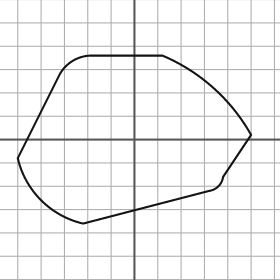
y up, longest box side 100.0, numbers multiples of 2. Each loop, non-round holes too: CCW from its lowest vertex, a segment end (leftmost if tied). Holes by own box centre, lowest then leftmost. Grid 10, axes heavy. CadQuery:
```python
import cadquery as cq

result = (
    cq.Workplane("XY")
    .moveTo(-22.0, -36.0)
    .lineTo(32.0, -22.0)
    .threePointArc((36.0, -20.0), (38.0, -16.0))
    .lineTo(50.0, 2.0)
    .threePointArc((34.0, 22.0), (12.0, 36.0))
    .lineTo(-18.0, 36.0)
    .threePointArc((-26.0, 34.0), (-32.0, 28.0))
    .lineTo(-50.0, -8.0)
    .threePointArc((-40.0, -26.0), (-22.0, -36.0))
    .close()
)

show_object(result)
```